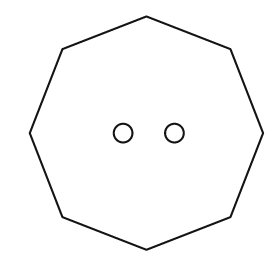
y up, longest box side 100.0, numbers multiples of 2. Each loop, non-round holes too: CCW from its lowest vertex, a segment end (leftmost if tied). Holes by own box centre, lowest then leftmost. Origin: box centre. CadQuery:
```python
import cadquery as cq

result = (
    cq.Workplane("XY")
    .moveTo(0.0, -50.0)
    .lineTo(36.0, -36.0)
    .lineTo(50.0, 0.0)
    .lineTo(36.0, 36.0)
    .lineTo(0.0, 50.0)
    .lineTo(-36.0, 36.0)
    .lineTo(-50.0, 0.0)
    .lineTo(-36.0, -36.0)
    .close()
    .moveTo(-10.0, 0.0)
    .circle(4.0)
    .moveTo(12.0, 0.0)
    .circle(4.0)
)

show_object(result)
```